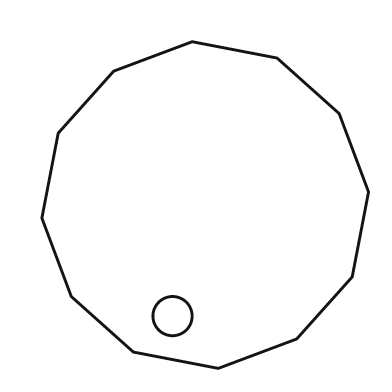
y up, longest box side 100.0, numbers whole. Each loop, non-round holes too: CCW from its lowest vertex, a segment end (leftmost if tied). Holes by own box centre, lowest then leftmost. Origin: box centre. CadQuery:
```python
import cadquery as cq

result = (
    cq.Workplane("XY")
    .moveTo(4.0, -50.0)
    .lineTo(28.0, -41.0)
    .lineTo(45.0, -22.0)
    .lineTo(50.0, 4.0)
    .lineTo(41.0, 28.0)
    .lineTo(22.0, 45.0)
    .lineTo(-4.0, 50.0)
    .lineTo(-28.0, 41.0)
    .lineTo(-45.0, 22.0)
    .lineTo(-50.0, -4.0)
    .lineTo(-41.0, -28.0)
    .lineTo(-22.0, -45.0)
    .close()
    .moveTo(-10.0, -34.0)
    .circle(6.0)
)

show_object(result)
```